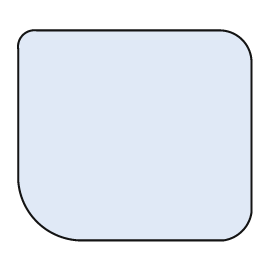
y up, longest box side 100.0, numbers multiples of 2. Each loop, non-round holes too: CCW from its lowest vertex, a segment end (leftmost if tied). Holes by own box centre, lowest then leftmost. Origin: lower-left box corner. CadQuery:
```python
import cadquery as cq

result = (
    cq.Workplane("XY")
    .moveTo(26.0, 0.0)
    .lineTo(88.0, 0.0)
    .threePointArc((96.0, 4.0), (100.0, 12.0))
    .lineTo(100.0, 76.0)
    .threePointArc((96.0, 86.0), (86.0, 90.0))
    .lineTo(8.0, 90.0)
    .threePointArc((2.0, 88.0), (0.0, 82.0))
    .lineTo(0.0, 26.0)
    .threePointArc((8.0, 8.0), (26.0, 0.0))
    .close()
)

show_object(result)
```